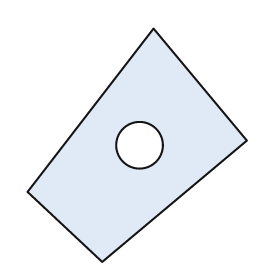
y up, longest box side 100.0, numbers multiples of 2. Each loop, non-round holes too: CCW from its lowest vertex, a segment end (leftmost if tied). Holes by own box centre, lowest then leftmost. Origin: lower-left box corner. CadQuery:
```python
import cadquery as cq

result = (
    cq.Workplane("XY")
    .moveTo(32.0, 0.0)
    .lineTo(94.0, 52.0)
    .lineTo(54.0, 100.0)
    .lineTo(0.0, 30.0)
    .close()
    .moveTo(48.0, 50.0)
    .circle(10.0)
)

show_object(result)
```